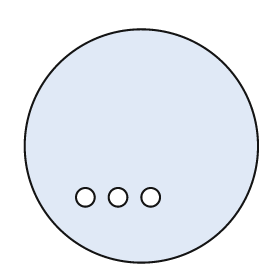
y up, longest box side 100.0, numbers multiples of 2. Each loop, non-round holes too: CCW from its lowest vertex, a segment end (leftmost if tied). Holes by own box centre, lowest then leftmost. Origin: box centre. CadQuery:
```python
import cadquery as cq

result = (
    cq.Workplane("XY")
    .moveTo(0.0, 0.0)
    .circle(50.0)
    .moveTo(-24.0, -22.0)
    .circle(4.0)
    .moveTo(-10.0, -22.0)
    .circle(4.0)
    .moveTo(4.0, -22.0)
    .circle(4.0)
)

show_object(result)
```